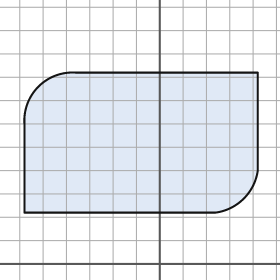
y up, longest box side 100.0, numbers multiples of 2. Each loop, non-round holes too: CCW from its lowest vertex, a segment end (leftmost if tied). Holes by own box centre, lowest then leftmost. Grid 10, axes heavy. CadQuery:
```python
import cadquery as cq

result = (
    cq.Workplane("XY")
    .moveTo(-58.0, 22.0)
    .lineTo(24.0, 22.0)
    .threePointArc((36.0, 28.0), (42.0, 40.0))
    .lineTo(42.0, 82.0)
    .lineTo(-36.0, 82.0)
    .threePointArc((-52.0, 76.0), (-58.0, 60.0))
    .close()
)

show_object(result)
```